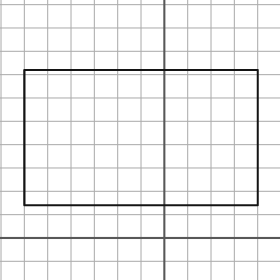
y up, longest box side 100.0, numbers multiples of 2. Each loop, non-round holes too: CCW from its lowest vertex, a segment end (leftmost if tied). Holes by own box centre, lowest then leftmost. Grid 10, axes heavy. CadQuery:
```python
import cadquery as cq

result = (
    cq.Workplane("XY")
    .moveTo(-60.0, 14.0)
    .lineTo(40.0, 14.0)
    .lineTo(40.0, 72.0)
    .lineTo(-60.0, 72.0)
    .close()
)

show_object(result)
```